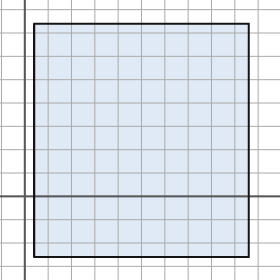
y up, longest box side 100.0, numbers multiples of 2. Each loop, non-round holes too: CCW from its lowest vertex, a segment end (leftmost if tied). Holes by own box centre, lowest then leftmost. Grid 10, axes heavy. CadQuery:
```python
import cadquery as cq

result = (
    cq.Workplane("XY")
    .moveTo(4.0, -26.0)
    .lineTo(96.0, -26.0)
    .lineTo(96.0, 74.0)
    .lineTo(4.0, 74.0)
    .close()
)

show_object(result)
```